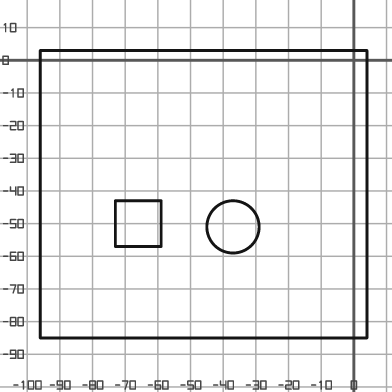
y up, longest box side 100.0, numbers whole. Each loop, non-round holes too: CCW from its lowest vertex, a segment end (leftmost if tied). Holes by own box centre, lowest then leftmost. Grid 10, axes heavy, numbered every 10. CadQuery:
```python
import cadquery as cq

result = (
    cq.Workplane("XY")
    .moveTo(-96.0, -85.0)
    .lineTo(4.0, -85.0)
    .lineTo(4.0, 3.0)
    .lineTo(-96.0, 3.0)
    .close()
    .moveTo(-37.0, -51.0)
    .circle(8.0)
    .moveTo(-73.0, -57.0)
    .lineTo(-59.0, -57.0)
    .lineTo(-59.0, -43.0)
    .lineTo(-73.0, -43.0)
    .close()
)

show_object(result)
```